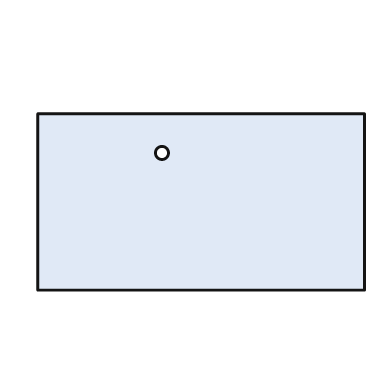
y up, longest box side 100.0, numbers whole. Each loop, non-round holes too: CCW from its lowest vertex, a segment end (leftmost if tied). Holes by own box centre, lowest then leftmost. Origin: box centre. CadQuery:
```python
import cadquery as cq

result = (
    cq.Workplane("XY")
    .moveTo(-50.0, -27.0)
    .lineTo(50.0, -27.0)
    .lineTo(50.0, 27.0)
    .lineTo(-50.0, 27.0)
    .close()
    .moveTo(-12.0, 15.0)
    .circle(2.0)
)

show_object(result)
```